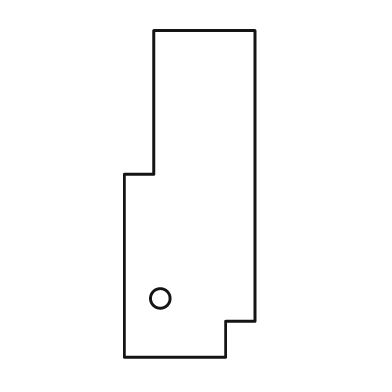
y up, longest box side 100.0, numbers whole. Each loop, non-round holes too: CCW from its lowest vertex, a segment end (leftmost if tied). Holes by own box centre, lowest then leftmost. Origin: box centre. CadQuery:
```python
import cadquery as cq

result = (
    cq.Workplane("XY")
    .moveTo(-20.0, -50.0)
    .lineTo(11.0, -50.0)
    .lineTo(11.0, -39.0)
    .lineTo(20.0, -39.0)
    .lineTo(20.0, 50.0)
    .lineTo(-11.0, 50.0)
    .lineTo(-11.0, 6.0)
    .lineTo(-20.0, 6.0)
    .close()
    .moveTo(-9.0, -32.0)
    .circle(3.0)
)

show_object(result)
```